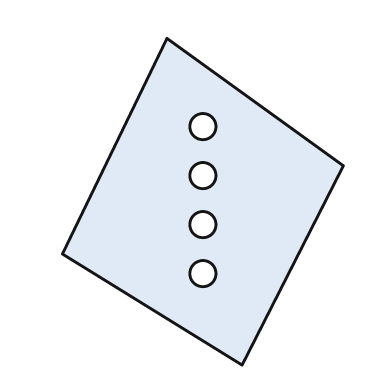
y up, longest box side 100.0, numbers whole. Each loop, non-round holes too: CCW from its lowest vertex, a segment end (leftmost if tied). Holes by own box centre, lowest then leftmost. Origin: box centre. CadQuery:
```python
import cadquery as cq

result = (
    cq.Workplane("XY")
    .moveTo(12.0, -50.0)
    .lineTo(43.0, 11.0)
    .lineTo(-11.0, 50.0)
    .lineTo(-43.0, -16.0)
    .close()
    .moveTo(0.0, -22.0)
    .circle(4.0)
    .moveTo(0.0, -7.0)
    .circle(4.0)
    .moveTo(0.0, 8.0)
    .circle(4.0)
    .moveTo(0.0, 23.0)
    .circle(4.0)
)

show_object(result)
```